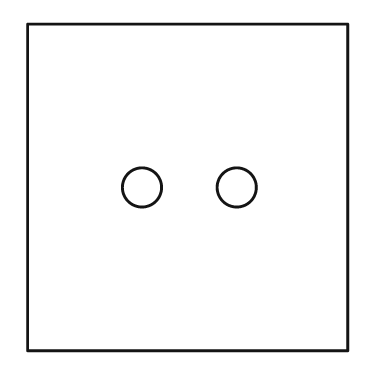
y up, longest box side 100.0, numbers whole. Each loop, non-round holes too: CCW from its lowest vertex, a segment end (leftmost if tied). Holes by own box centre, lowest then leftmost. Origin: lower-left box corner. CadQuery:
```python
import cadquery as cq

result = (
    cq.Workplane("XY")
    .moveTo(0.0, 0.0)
    .lineTo(98.0, 0.0)
    .lineTo(98.0, 100.0)
    .lineTo(0.0, 100.0)
    .close()
    .moveTo(35.0, 50.0)
    .circle(6.0)
    .moveTo(64.0, 50.0)
    .circle(6.0)
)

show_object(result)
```